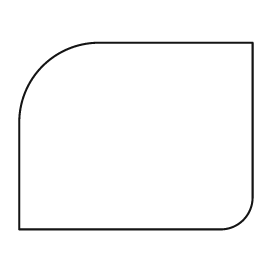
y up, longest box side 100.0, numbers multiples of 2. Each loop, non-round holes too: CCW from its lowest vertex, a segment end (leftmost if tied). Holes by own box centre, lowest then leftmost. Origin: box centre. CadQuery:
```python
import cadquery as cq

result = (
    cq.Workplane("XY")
    .moveTo(-50.0, -40.0)
    .lineTo(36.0, -40.0)
    .threePointArc((46.0, -36.0), (50.0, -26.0))
    .lineTo(50.0, 40.0)
    .lineTo(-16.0, 40.0)
    .threePointArc((-40.0, 30.0), (-50.0, 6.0))
    .close()
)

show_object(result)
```